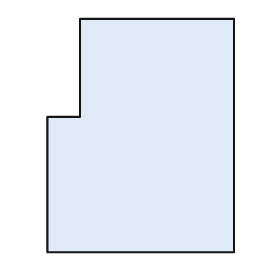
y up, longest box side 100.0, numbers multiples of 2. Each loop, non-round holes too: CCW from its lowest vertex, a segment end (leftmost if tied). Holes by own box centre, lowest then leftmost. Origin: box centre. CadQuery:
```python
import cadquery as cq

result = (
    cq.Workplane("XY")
    .moveTo(-40.0, -50.0)
    .lineTo(40.0, -50.0)
    .lineTo(40.0, 50.0)
    .lineTo(-26.0, 50.0)
    .lineTo(-26.0, 8.0)
    .lineTo(-40.0, 8.0)
    .close()
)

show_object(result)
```